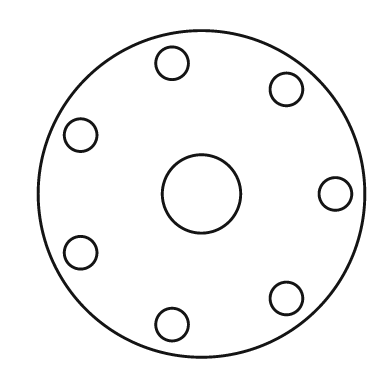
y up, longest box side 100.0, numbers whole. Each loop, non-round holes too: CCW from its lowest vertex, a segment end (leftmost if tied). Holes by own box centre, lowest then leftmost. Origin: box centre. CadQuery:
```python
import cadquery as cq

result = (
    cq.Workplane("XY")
    .moveTo(0.0, 0.0)
    .circle(50.0)
    .moveTo(-9.0, -40.0)
    .circle(5.0)
    .moveTo(26.0, -32.0)
    .circle(5.0)
    .moveTo(-37.0, -18.0)
    .circle(5.0)
    .moveTo(0.0, 0.0)
    .circle(12.0)
    .moveTo(41.0, 0.0)
    .circle(5.0)
    .moveTo(-37.0, 18.0)
    .circle(5.0)
    .moveTo(26.0, 32.0)
    .circle(5.0)
    .moveTo(-9.0, 40.0)
    .circle(5.0)
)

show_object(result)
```